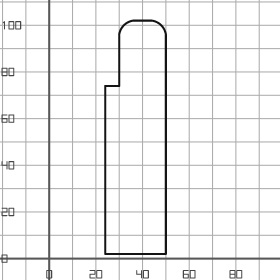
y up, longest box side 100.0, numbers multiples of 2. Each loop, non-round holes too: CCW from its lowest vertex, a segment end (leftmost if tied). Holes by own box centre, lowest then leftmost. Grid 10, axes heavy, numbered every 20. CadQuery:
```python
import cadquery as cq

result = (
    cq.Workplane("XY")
    .moveTo(24.0, 2.0)
    .lineTo(50.0, 2.0)
    .lineTo(50.0, 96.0)
    .threePointArc((48.0, 100.0), (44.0, 102.0))
    .lineTo(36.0, 102.0)
    .threePointArc((32.0, 100.0), (30.0, 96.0))
    .lineTo(30.0, 74.0)
    .lineTo(24.0, 74.0)
    .close()
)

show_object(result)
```